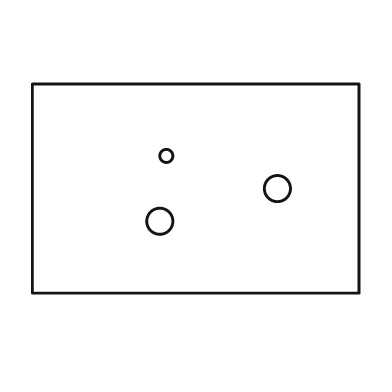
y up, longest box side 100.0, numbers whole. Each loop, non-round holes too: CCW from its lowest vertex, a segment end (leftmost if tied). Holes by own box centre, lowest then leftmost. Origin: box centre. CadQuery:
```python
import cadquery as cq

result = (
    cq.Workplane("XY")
    .moveTo(-50.0, -32.0)
    .lineTo(50.0, -32.0)
    .lineTo(50.0, 32.0)
    .lineTo(-50.0, 32.0)
    .close()
    .moveTo(-11.0, -10.0)
    .circle(4.0)
    .moveTo(25.0, 0.0)
    .circle(4.0)
    .moveTo(-9.0, 10.0)
    .circle(2.0)
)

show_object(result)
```